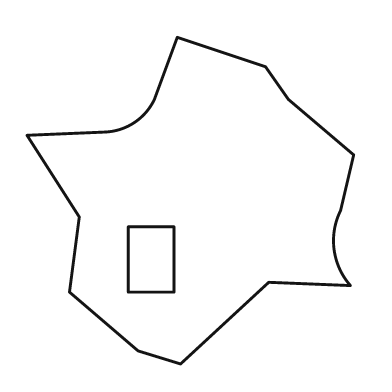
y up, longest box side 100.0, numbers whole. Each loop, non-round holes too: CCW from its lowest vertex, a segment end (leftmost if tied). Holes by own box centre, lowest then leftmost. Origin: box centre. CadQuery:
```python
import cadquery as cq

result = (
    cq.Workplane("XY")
    .moveTo(-3.0, -50.0)
    .lineTo(24.0, -25.0)
    .lineTo(49.0, -26.0)
    .threePointArc((44.0, -15.0), (46.0, -3.0))
    .lineTo(50.0, 14.0)
    .lineTo(30.0, 31.0)
    .lineTo(23.0, 41.0)
    .lineTo(-4.0, 50.0)
    .lineTo(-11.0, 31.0)
    .threePointArc((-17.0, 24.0), (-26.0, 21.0))
    .lineTo(-50.0, 20.0)
    .lineTo(-34.0, -5.0)
    .lineTo(-37.0, -28.0)
    .lineTo(-16.0, -46.0)
    .close()
    .moveTo(-19.0, -28.0)
    .lineTo(-5.0, -28.0)
    .lineTo(-5.0, -8.0)
    .lineTo(-19.0, -8.0)
    .close()
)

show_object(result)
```